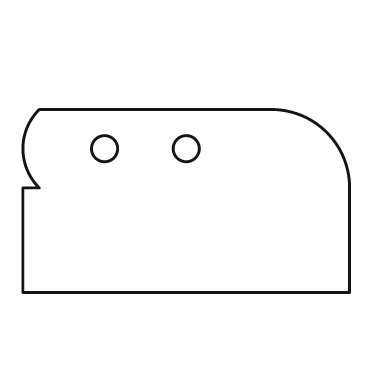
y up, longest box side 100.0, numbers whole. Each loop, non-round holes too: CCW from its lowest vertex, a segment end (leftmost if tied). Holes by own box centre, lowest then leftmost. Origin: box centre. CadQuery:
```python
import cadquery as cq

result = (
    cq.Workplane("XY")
    .moveTo(-50.0, -28.0)
    .lineTo(50.0, -28.0)
    .lineTo(50.0, 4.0)
    .threePointArc((43.0, 21.0), (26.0, 28.0))
    .lineTo(-45.0, 28.0)
    .threePointArc((-50.0, 16.0), (-45.0, 4.0))
    .lineTo(-50.0, 4.0)
    .close()
    .moveTo(-25.0, 16.0)
    .circle(4.0)
    .moveTo(0.0, 16.0)
    .circle(4.0)
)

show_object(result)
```